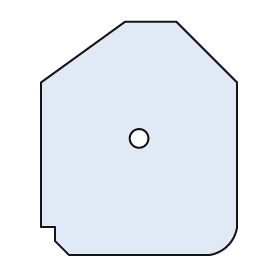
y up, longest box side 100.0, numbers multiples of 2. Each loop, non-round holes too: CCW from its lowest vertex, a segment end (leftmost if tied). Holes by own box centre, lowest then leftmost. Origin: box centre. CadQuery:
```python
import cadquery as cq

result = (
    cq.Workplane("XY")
    .moveTo(-30.0, -50.0)
    .lineTo(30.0, -50.0)
    .threePointArc((38.0, -46.0), (42.0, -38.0))
    .lineTo(42.0, 24.0)
    .lineTo(16.0, 50.0)
    .lineTo(-6.0, 50.0)
    .lineTo(-42.0, 24.0)
    .lineTo(-42.0, -38.0)
    .lineTo(-36.0, -38.0)
    .lineTo(-36.0, -44.0)
    .close()
    .moveTo(0.0, 0.0)
    .circle(4.0)
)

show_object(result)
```